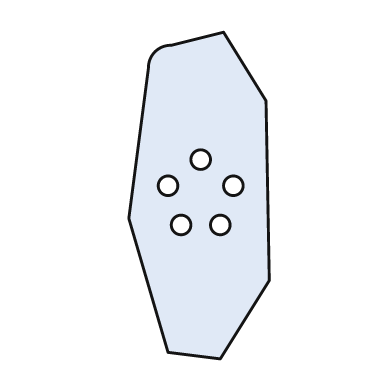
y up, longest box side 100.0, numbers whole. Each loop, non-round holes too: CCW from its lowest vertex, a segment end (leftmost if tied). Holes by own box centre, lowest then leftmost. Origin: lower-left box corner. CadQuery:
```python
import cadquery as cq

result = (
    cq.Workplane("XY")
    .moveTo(28.0, 0.0)
    .lineTo(43.0, 24.0)
    .lineTo(42.0, 79.0)
    .lineTo(29.0, 100.0)
    .lineTo(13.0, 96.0)
    .threePointArc((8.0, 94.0), (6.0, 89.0))
    .lineTo(0.0, 43.0)
    .lineTo(12.0, 2.0)
    .close()
    .moveTo(16.0, 41.0)
    .circle(3.0)
    .moveTo(28.0, 41.0)
    .circle(3.0)
    .moveTo(12.0, 53.0)
    .circle(3.0)
    .moveTo(32.0, 53.0)
    .circle(3.0)
    .moveTo(22.0, 61.0)
    .circle(3.0)
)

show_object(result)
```